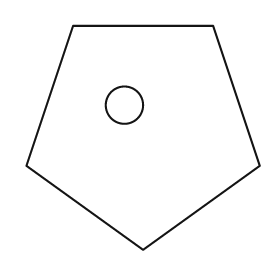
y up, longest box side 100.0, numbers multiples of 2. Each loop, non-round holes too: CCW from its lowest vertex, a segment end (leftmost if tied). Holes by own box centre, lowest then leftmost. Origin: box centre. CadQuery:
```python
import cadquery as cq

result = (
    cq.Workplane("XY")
    .moveTo(0.0, -48.0)
    .lineTo(50.0, -12.0)
    .lineTo(30.0, 48.0)
    .lineTo(-30.0, 48.0)
    .lineTo(-50.0, -12.0)
    .close()
    .moveTo(-8.0, 14.0)
    .circle(8.0)
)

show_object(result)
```